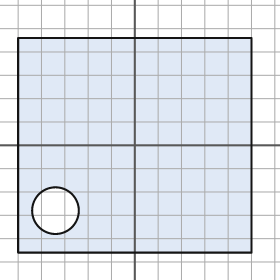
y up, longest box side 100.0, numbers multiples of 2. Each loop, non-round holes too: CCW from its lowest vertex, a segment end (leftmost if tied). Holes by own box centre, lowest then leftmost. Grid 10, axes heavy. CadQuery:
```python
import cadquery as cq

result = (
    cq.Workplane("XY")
    .moveTo(-50.0, -46.0)
    .lineTo(50.0, -46.0)
    .lineTo(50.0, 46.0)
    .lineTo(-50.0, 46.0)
    .close()
    .moveTo(-34.0, -28.0)
    .circle(10.0)
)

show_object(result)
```